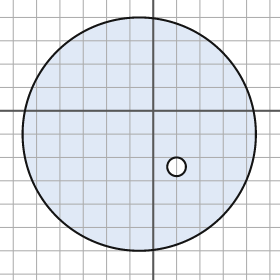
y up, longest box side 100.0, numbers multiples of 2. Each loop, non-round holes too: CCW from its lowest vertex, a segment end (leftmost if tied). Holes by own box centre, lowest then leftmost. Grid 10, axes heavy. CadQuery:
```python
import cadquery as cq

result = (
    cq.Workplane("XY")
    .moveTo(-6.0, -10.0)
    .circle(50.0)
    .moveTo(10.0, -24.0)
    .circle(4.0)
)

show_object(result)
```